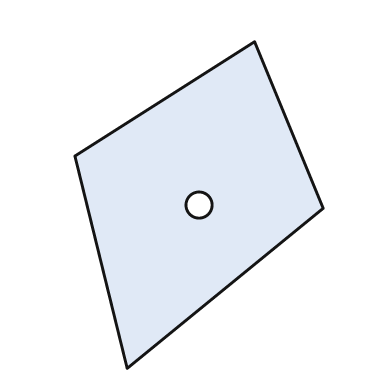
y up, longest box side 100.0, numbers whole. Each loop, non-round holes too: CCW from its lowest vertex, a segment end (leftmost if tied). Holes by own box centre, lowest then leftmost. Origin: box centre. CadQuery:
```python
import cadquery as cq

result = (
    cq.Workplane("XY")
    .moveTo(-22.0, -50.0)
    .lineTo(38.0, -1.0)
    .lineTo(17.0, 50.0)
    .lineTo(-38.0, 15.0)
    .close()
    .moveTo(0.0, 0.0)
    .circle(4.0)
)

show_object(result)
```